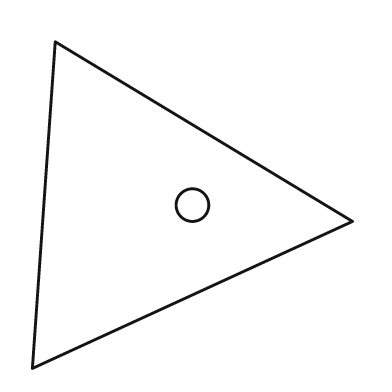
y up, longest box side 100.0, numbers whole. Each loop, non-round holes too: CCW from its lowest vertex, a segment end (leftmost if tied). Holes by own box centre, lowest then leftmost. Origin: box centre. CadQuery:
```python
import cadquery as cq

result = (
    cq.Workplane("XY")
    .moveTo(-49.0, -50.0)
    .lineTo(49.0, -5.0)
    .lineTo(-42.0, 50.0)
    .close()
    .moveTo(0.0, 0.0)
    .circle(5.0)
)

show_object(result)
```